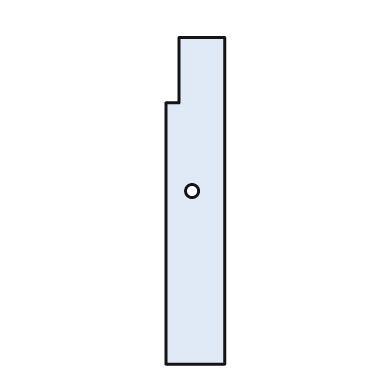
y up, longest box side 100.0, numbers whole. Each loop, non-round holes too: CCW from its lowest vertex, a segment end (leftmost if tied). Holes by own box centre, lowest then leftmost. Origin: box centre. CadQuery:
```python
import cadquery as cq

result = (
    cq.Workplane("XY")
    .moveTo(-9.0, -50.0)
    .lineTo(9.0, -50.0)
    .lineTo(9.0, 50.0)
    .lineTo(-5.0, 50.0)
    .lineTo(-5.0, 30.0)
    .lineTo(-9.0, 30.0)
    .close()
    .moveTo(-1.0, 3.0)
    .circle(2.0)
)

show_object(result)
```